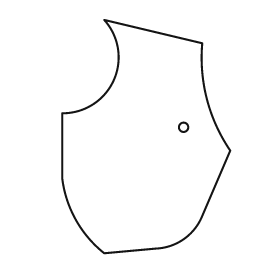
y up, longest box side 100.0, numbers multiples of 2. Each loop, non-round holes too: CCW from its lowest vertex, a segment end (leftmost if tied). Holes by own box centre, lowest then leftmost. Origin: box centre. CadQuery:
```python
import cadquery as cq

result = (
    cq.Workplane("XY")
    .moveTo(-18.0, -50.0)
    .lineTo(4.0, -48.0)
    .threePointArc((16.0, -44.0), (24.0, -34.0))
    .lineTo(36.0, -6.0)
    .threePointArc((26.0, 16.0), (24.0, 40.0))
    .lineTo(-18.0, 50.0)
    .threePointArc((-14.0, 24.0), (-36.0, 10.0))
    .lineTo(-36.0, -18.0)
    .threePointArc((-30.0, -36.0), (-18.0, -50.0))
    .close()
    .moveTo(16.0, 4.0)
    .circle(2.0)
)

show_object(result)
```